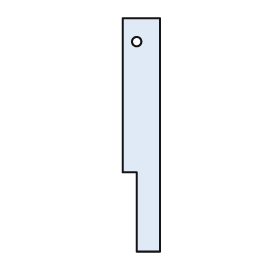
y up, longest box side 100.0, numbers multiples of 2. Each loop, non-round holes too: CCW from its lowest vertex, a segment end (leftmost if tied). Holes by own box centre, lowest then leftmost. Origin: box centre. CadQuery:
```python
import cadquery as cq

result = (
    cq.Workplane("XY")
    .moveTo(-2.0, -50.0)
    .lineTo(8.0, -50.0)
    .lineTo(8.0, 50.0)
    .lineTo(-8.0, 50.0)
    .lineTo(-8.0, -16.0)
    .lineTo(-2.0, -16.0)
    .close()
    .moveTo(-2.0, 40.0)
    .circle(2.0)
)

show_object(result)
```